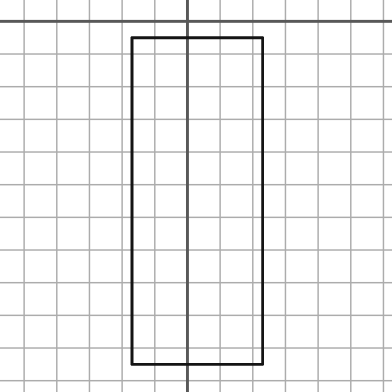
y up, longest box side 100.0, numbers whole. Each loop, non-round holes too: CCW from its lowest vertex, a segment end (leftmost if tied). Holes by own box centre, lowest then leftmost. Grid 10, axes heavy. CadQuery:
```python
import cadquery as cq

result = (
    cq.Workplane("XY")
    .moveTo(-17.0, -105.0)
    .lineTo(23.0, -105.0)
    .lineTo(23.0, -5.0)
    .lineTo(-17.0, -5.0)
    .close()
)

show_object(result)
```